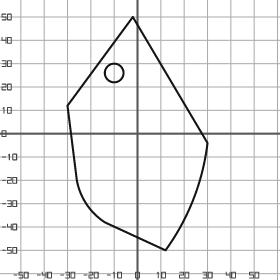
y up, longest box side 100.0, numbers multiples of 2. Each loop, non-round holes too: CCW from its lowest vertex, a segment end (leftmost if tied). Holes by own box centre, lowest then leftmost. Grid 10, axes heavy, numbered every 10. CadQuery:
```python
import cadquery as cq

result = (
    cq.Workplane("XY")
    .moveTo(12.0, -50.0)
    .threePointArc((24.0, -28.0), (30.0, -4.0))
    .lineTo(-2.0, 50.0)
    .lineTo(-30.0, 12.0)
    .lineTo(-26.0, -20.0)
    .threePointArc((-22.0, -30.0), (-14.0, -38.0))
    .close()
    .moveTo(-10.0, 26.0)
    .circle(4.0)
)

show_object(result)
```